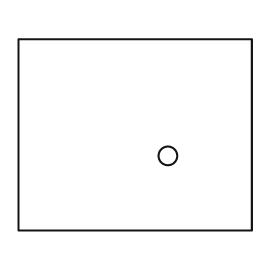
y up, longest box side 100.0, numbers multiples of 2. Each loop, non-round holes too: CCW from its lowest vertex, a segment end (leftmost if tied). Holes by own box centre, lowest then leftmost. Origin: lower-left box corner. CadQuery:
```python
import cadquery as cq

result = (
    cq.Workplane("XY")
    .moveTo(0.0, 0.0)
    .lineTo(100.0, 0.0)
    .lineTo(100.0, 82.0)
    .lineTo(0.0, 82.0)
    .close()
    .moveTo(64.0, 32.0)
    .circle(4.0)
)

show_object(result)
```